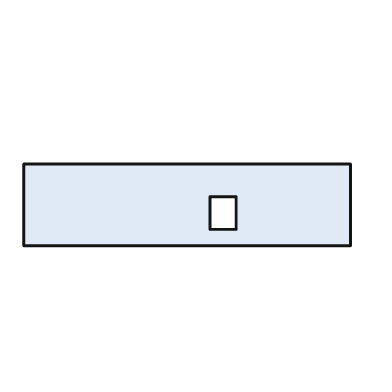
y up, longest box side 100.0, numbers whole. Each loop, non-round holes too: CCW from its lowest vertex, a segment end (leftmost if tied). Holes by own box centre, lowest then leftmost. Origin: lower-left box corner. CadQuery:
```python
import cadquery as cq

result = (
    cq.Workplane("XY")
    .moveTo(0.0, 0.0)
    .lineTo(100.0, 0.0)
    .lineTo(100.0, 25.0)
    .lineTo(0.0, 25.0)
    .close()
    .moveTo(57.0, 5.0)
    .lineTo(65.0, 5.0)
    .lineTo(65.0, 15.0)
    .lineTo(57.0, 15.0)
    .close()
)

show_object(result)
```